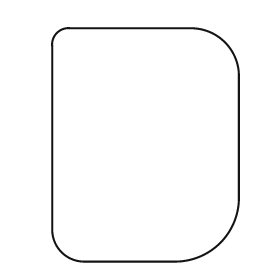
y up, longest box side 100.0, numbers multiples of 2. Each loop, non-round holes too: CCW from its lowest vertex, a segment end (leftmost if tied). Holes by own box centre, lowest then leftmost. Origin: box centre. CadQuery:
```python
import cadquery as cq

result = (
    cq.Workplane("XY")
    .moveTo(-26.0, -50.0)
    .lineTo(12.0, -50.0)
    .threePointArc((32.0, -42.0), (40.0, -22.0))
    .lineTo(40.0, 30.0)
    .threePointArc((34.0, 44.0), (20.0, 50.0))
    .lineTo(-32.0, 50.0)
    .threePointArc((-38.0, 48.0), (-40.0, 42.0))
    .lineTo(-40.0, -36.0)
    .threePointArc((-36.0, -46.0), (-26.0, -50.0))
    .close()
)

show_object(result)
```